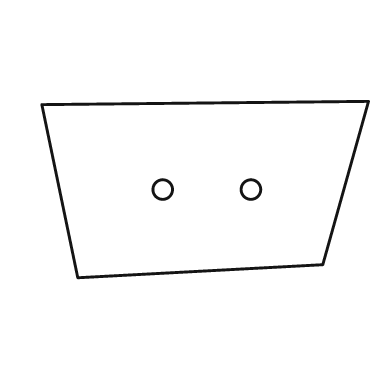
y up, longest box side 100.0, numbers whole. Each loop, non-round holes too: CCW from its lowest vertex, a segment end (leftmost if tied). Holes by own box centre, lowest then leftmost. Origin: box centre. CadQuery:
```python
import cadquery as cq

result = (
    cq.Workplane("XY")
    .moveTo(-39.0, -27.0)
    .lineTo(36.0, -23.0)
    .lineTo(50.0, 27.0)
    .lineTo(-50.0, 26.0)
    .close()
    .moveTo(-13.0, 0.0)
    .circle(3.0)
    .moveTo(14.0, 0.0)
    .circle(3.0)
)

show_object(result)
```